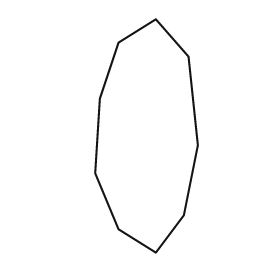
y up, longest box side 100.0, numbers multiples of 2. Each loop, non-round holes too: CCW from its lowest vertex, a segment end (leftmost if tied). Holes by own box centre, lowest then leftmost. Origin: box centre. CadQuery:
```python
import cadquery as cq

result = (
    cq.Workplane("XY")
    .moveTo(4.0, -50.0)
    .lineTo(16.0, -34.0)
    .lineTo(22.0, -4.0)
    .lineTo(18.0, 34.0)
    .lineTo(4.0, 50.0)
    .lineTo(-12.0, 40.0)
    .lineTo(-20.0, 16.0)
    .lineTo(-22.0, -16.0)
    .lineTo(-12.0, -40.0)
    .close()
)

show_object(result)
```